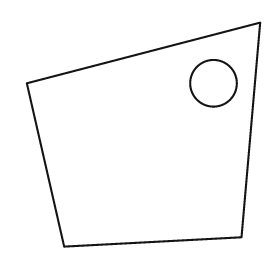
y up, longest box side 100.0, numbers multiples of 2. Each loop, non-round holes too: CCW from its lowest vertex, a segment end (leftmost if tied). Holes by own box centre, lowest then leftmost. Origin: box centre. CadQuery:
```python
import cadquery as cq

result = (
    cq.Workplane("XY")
    .moveTo(-34.0, -48.0)
    .lineTo(42.0, -44.0)
    .lineTo(50.0, 48.0)
    .lineTo(-50.0, 22.0)
    .close()
    .moveTo(30.0, 22.0)
    .circle(10.0)
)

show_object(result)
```